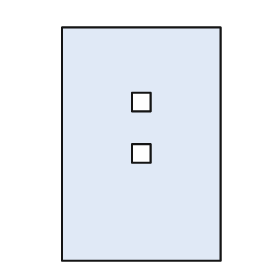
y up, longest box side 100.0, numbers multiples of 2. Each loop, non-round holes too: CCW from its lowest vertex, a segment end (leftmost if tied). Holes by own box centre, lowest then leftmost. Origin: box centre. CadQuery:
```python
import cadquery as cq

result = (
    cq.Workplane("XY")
    .moveTo(-34.0, -50.0)
    .lineTo(34.0, -50.0)
    .lineTo(34.0, 50.0)
    .lineTo(-34.0, 50.0)
    .close()
    .moveTo(-4.0, -8.0)
    .lineTo(4.0, -8.0)
    .lineTo(4.0, 0.0)
    .lineTo(-4.0, 0.0)
    .close()
    .moveTo(-4.0, 14.0)
    .lineTo(4.0, 14.0)
    .lineTo(4.0, 22.0)
    .lineTo(-4.0, 22.0)
    .close()
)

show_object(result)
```